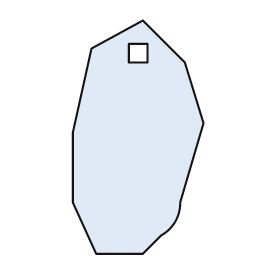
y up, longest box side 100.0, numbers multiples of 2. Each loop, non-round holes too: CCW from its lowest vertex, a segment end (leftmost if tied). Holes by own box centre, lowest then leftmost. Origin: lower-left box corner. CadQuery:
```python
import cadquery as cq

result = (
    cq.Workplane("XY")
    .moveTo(10.0, 0.0)
    .lineTo(30.0, 0.0)
    .lineTo(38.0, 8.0)
    .threePointArc((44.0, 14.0), (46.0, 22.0))
    .lineTo(56.0, 56.0)
    .lineTo(48.0, 82.0)
    .lineTo(30.0, 100.0)
    .lineTo(8.0, 88.0)
    .lineTo(0.0, 52.0)
    .lineTo(0.0, 22.0)
    .close()
    .moveTo(24.0, 82.0)
    .lineTo(32.0, 82.0)
    .lineTo(32.0, 90.0)
    .lineTo(24.0, 90.0)
    .close()
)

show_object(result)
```